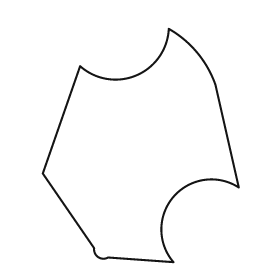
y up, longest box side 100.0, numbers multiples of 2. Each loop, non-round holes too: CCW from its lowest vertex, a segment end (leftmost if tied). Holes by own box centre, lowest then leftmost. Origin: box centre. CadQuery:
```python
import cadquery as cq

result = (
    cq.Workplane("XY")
    .moveTo(14.0, -50.0)
    .threePointArc((14.0, -22.0), (42.0, -18.0))
    .lineTo(32.0, 26.0)
    .threePointArc((24.0, 40.0), (12.0, 50.0))
    .threePointArc((-2.0, 30.0), (-26.0, 34.0))
    .lineTo(-42.0, -12.0)
    .lineTo(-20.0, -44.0)
    .threePointArc((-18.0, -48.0), (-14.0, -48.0))
    .close()
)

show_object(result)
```